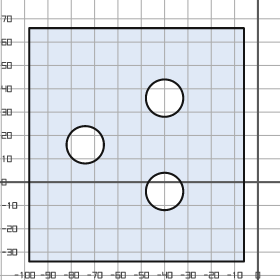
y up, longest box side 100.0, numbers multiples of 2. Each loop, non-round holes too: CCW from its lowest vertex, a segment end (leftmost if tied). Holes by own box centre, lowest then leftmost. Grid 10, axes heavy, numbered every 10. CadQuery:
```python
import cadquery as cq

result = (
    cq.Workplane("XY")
    .moveTo(-98.0, -34.0)
    .lineTo(-6.0, -34.0)
    .lineTo(-6.0, 66.0)
    .lineTo(-98.0, 66.0)
    .close()
    .moveTo(-40.0, -4.0)
    .circle(8.0)
    .moveTo(-74.0, 16.0)
    .circle(8.0)
    .moveTo(-40.0, 36.0)
    .circle(8.0)
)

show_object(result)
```